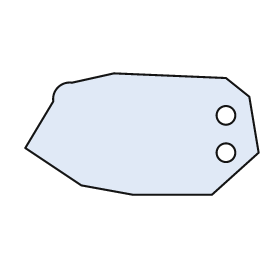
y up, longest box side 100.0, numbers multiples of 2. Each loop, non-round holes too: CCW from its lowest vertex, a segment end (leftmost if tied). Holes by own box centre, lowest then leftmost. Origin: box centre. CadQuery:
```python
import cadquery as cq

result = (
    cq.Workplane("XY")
    .moveTo(-4.0, -26.0)
    .lineTo(30.0, -26.0)
    .lineTo(50.0, -8.0)
    .lineTo(46.0, 16.0)
    .lineTo(36.0, 24.0)
    .lineTo(-12.0, 26.0)
    .lineTo(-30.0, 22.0)
    .threePointArc((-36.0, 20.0), (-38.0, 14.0))
    .lineTo(-50.0, -6.0)
    .lineTo(-26.0, -22.0)
    .close()
    .moveTo(36.0, -8.0)
    .circle(4.0)
    .moveTo(36.0, 8.0)
    .circle(4.0)
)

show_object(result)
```